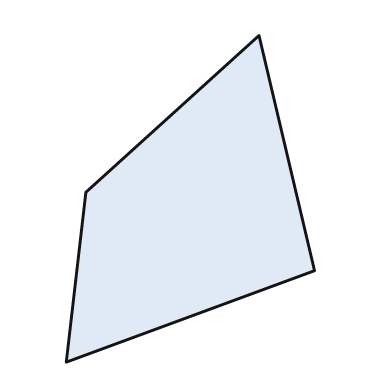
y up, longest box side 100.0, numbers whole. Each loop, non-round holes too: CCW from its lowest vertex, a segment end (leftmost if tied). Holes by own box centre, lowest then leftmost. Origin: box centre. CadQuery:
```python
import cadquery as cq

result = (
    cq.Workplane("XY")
    .moveTo(-38.0, -50.0)
    .lineTo(38.0, -22.0)
    .lineTo(21.0, 50.0)
    .lineTo(-32.0, 2.0)
    .close()
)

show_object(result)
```